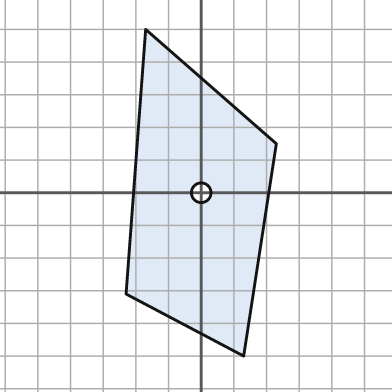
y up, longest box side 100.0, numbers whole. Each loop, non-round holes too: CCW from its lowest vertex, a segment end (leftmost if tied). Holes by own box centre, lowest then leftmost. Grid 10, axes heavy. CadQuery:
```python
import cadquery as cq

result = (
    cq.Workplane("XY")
    .moveTo(13.0, -50.0)
    .lineTo(23.0, 15.0)
    .lineTo(-17.0, 50.0)
    .lineTo(-23.0, -31.0)
    .close()
    .moveTo(0.0, 0.0)
    .circle(3.0)
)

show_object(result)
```